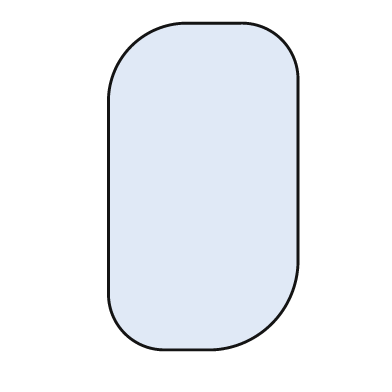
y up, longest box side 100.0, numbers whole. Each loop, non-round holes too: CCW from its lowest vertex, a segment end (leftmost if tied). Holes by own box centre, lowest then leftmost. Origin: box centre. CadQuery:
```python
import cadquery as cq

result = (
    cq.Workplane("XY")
    .moveTo(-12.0, -50.0)
    .lineTo(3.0, -50.0)
    .threePointArc((21.0, -42.0), (29.0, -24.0))
    .lineTo(29.0, 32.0)
    .threePointArc((24.0, 45.0), (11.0, 50.0))
    .lineTo(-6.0, 50.0)
    .threePointArc((-22.0, 43.0), (-29.0, 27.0))
    .lineTo(-29.0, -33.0)
    .threePointArc((-24.0, -45.0), (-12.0, -50.0))
    .close()
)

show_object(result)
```